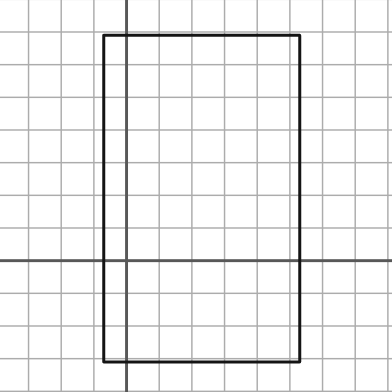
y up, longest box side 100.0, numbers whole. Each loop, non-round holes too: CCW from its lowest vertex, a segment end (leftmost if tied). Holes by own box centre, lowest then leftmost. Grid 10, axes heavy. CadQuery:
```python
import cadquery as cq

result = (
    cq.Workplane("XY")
    .moveTo(-7.0, -31.0)
    .lineTo(53.0, -31.0)
    .lineTo(53.0, 69.0)
    .lineTo(-7.0, 69.0)
    .close()
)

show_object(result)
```